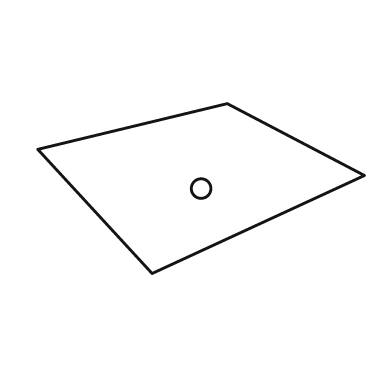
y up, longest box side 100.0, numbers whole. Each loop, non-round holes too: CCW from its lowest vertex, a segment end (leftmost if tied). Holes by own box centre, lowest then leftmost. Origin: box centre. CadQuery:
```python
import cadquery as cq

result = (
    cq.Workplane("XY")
    .moveTo(-15.0, -26.0)
    .lineTo(50.0, 4.0)
    .lineTo(8.0, 26.0)
    .lineTo(-50.0, 12.0)
    .close()
    .moveTo(0.0, 0.0)
    .circle(3.0)
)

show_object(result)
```